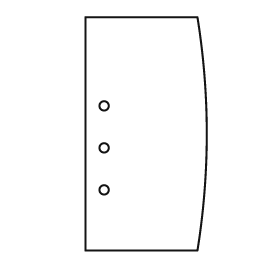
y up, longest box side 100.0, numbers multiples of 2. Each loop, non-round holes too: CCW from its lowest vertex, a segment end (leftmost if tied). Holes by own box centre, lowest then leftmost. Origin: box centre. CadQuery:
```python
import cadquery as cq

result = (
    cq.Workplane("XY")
    .moveTo(-26.0, -50.0)
    .lineTo(22.0, -50.0)
    .threePointArc((26.0, 0.0), (22.0, 50.0))
    .lineTo(-26.0, 50.0)
    .close()
    .moveTo(-18.0, -24.0)
    .circle(2.0)
    .moveTo(-18.0, -6.0)
    .circle(2.0)
    .moveTo(-18.0, 12.0)
    .circle(2.0)
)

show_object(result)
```